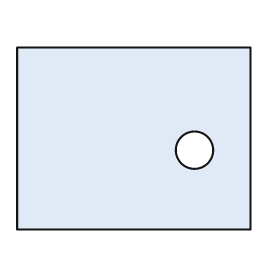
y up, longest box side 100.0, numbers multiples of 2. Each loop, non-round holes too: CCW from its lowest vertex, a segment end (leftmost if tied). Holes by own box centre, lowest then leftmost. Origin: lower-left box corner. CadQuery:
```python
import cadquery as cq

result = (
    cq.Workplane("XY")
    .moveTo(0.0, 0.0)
    .lineTo(100.0, 0.0)
    .lineTo(100.0, 78.0)
    .lineTo(0.0, 78.0)
    .close()
    .moveTo(76.0, 34.0)
    .circle(8.0)
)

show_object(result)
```